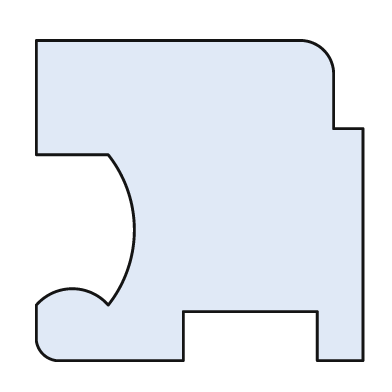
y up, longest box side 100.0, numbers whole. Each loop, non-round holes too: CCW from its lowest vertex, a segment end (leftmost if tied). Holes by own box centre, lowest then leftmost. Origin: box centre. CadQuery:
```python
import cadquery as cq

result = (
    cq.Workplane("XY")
    .moveTo(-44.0, -49.0)
    .lineTo(-5.0, -49.0)
    .lineTo(-5.0, -34.0)
    .lineTo(36.0, -34.0)
    .lineTo(36.0, -49.0)
    .lineTo(50.0, -49.0)
    .lineTo(50.0, 22.0)
    .lineTo(41.0, 22.0)
    .lineTo(41.0, 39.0)
    .threePointArc((38.0, 46.0), (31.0, 49.0))
    .lineTo(-50.0, 49.0)
    .lineTo(-50.0, 14.0)
    .lineTo(-28.0, 14.0)
    .threePointArc((-20.0, -9.0), (-28.0, -32.0))
    .threePointArc((-39.0, -27.0), (-50.0, -32.0))
    .lineTo(-50.0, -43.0)
    .threePointArc((-48.0, -47.0), (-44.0, -49.0))
    .close()
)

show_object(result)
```